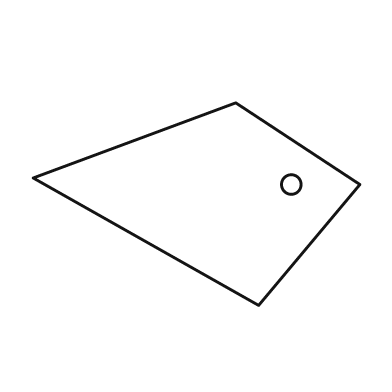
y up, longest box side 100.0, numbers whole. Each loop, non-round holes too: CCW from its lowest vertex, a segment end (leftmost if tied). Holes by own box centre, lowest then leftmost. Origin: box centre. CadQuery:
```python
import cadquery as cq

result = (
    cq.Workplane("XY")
    .moveTo(19.0, -31.0)
    .lineTo(50.0, 6.0)
    .lineTo(12.0, 31.0)
    .lineTo(-50.0, 8.0)
    .close()
    .moveTo(29.0, 6.0)
    .circle(3.0)
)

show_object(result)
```